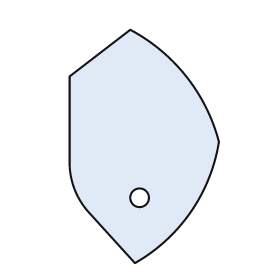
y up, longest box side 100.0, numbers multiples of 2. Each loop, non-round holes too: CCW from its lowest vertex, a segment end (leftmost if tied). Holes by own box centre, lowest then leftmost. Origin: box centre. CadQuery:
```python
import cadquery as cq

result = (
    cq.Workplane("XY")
    .moveTo(-4.0, -50.0)
    .threePointArc((20.0, -28.0), (32.0, 2.0))
    .threePointArc((18.0, 30.0), (-6.0, 50.0))
    .lineTo(-32.0, 30.0)
    .lineTo(-32.0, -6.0)
    .threePointArc((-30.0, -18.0), (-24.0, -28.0))
    .close()
    .moveTo(-2.0, -22.0)
    .circle(4.0)
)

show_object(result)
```